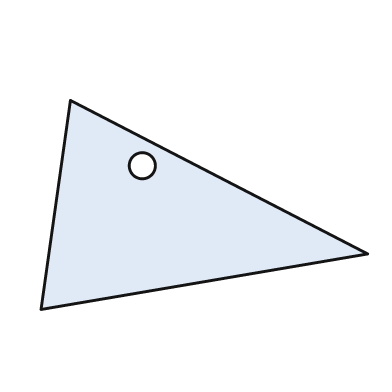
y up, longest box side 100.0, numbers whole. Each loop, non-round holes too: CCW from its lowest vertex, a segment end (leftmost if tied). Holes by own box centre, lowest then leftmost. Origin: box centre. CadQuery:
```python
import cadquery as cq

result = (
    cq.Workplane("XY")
    .moveTo(-50.0, -32.0)
    .lineTo(50.0, -15.0)
    .lineTo(-41.0, 32.0)
    .close()
    .moveTo(-19.0, 12.0)
    .circle(4.0)
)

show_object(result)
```